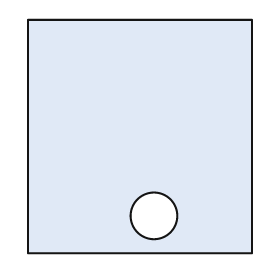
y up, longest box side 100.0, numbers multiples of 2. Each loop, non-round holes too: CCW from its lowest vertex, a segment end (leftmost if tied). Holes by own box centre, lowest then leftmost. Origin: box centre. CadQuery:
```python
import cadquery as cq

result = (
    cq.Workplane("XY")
    .moveTo(-48.0, -50.0)
    .lineTo(48.0, -50.0)
    .lineTo(48.0, 50.0)
    .lineTo(-48.0, 50.0)
    .close()
    .moveTo(6.0, -34.0)
    .circle(10.0)
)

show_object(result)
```